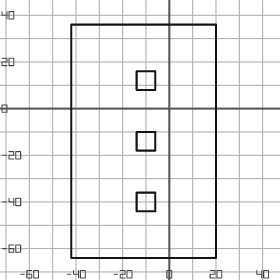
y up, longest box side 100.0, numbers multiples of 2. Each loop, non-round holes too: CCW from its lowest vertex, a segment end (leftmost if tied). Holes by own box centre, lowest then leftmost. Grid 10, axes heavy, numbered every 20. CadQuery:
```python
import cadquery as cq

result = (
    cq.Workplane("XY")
    .moveTo(-42.0, -64.0)
    .lineTo(20.0, -64.0)
    .lineTo(20.0, 36.0)
    .lineTo(-42.0, 36.0)
    .close()
    .moveTo(-14.0, -44.0)
    .lineTo(-6.0, -44.0)
    .lineTo(-6.0, -36.0)
    .lineTo(-14.0, -36.0)
    .close()
    .moveTo(-14.0, -18.0)
    .lineTo(-6.0, -18.0)
    .lineTo(-6.0, -10.0)
    .lineTo(-14.0, -10.0)
    .close()
    .moveTo(-14.0, 8.0)
    .lineTo(-6.0, 8.0)
    .lineTo(-6.0, 16.0)
    .lineTo(-14.0, 16.0)
    .close()
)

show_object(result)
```